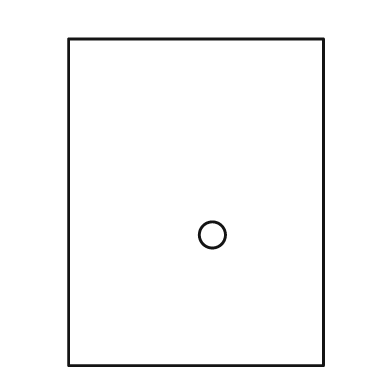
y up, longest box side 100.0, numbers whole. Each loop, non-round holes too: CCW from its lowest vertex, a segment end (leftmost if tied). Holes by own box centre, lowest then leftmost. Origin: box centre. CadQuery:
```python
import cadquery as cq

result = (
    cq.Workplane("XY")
    .moveTo(-39.0, -50.0)
    .lineTo(39.0, -50.0)
    .lineTo(39.0, 50.0)
    .lineTo(-39.0, 50.0)
    .close()
    .moveTo(5.0, -10.0)
    .circle(4.0)
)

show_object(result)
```